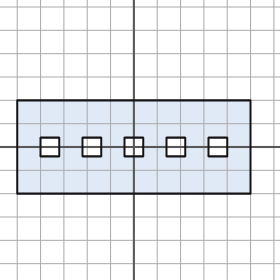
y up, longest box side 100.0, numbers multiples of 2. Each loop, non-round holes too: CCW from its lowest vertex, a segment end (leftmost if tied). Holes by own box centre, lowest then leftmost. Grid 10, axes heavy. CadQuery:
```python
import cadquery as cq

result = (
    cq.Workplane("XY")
    .moveTo(-50.0, -20.0)
    .lineTo(50.0, -20.0)
    .lineTo(50.0, 20.0)
    .lineTo(-50.0, 20.0)
    .close()
    .moveTo(-40.0, -4.0)
    .lineTo(-32.0, -4.0)
    .lineTo(-32.0, 4.0)
    .lineTo(-40.0, 4.0)
    .close()
    .moveTo(-22.0, -4.0)
    .lineTo(-14.0, -4.0)
    .lineTo(-14.0, 4.0)
    .lineTo(-22.0, 4.0)
    .close()
    .moveTo(-4.0, -4.0)
    .lineTo(4.0, -4.0)
    .lineTo(4.0, 4.0)
    .lineTo(-4.0, 4.0)
    .close()
    .moveTo(14.0, -4.0)
    .lineTo(22.0, -4.0)
    .lineTo(22.0, 4.0)
    .lineTo(14.0, 4.0)
    .close()
    .moveTo(32.0, -4.0)
    .lineTo(40.0, -4.0)
    .lineTo(40.0, 4.0)
    .lineTo(32.0, 4.0)
    .close()
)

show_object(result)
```